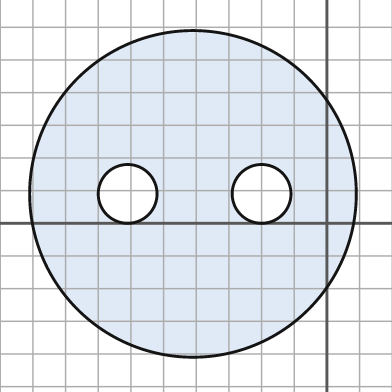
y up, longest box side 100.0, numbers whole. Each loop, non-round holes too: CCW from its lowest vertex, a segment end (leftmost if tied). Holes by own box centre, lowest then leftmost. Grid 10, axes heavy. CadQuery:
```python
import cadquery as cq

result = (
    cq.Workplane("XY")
    .moveTo(-41.0, 9.0)
    .circle(50.0)
    .moveTo(-61.0, 9.0)
    .circle(9.0)
    .moveTo(-20.0, 9.0)
    .circle(9.0)
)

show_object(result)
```